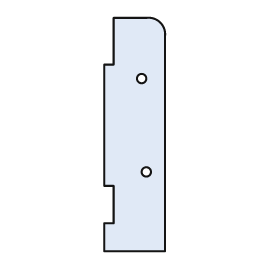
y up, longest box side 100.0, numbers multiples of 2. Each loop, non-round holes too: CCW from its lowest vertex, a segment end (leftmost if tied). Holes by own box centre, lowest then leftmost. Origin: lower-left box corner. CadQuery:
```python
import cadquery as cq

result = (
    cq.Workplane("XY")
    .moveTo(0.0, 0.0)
    .lineTo(26.0, 0.0)
    .lineTo(26.0, 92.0)
    .threePointArc((24.0, 98.0), (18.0, 100.0))
    .lineTo(4.0, 100.0)
    .lineTo(4.0, 80.0)
    .lineTo(0.0, 80.0)
    .lineTo(0.0, 28.0)
    .lineTo(4.0, 28.0)
    .lineTo(4.0, 12.0)
    .lineTo(0.0, 12.0)
    .close()
    .moveTo(18.0, 34.0)
    .circle(2.0)
    .moveTo(16.0, 74.0)
    .circle(2.0)
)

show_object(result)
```